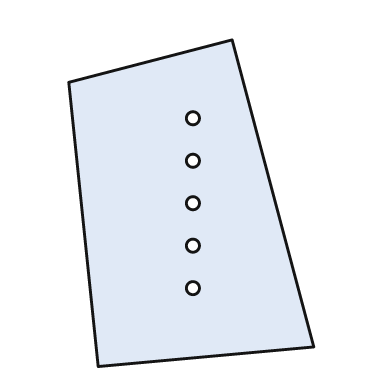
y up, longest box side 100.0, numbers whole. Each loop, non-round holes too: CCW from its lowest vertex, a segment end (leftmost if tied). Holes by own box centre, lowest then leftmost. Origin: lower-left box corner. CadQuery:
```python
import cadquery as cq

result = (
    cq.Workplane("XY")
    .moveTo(9.0, 0.0)
    .lineTo(75.0, 6.0)
    .lineTo(50.0, 100.0)
    .lineTo(0.0, 87.0)
    .close()
    .moveTo(38.0, 24.0)
    .circle(2.0)
    .moveTo(38.0, 37.0)
    .circle(2.0)
    .moveTo(38.0, 50.0)
    .circle(2.0)
    .moveTo(38.0, 63.0)
    .circle(2.0)
    .moveTo(38.0, 76.0)
    .circle(2.0)
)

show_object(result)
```